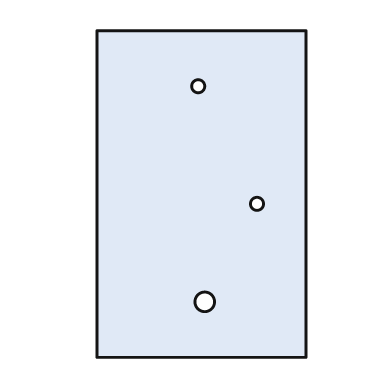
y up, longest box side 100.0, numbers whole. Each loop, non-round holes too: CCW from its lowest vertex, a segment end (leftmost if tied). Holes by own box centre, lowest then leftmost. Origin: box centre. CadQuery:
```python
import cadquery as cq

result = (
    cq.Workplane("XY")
    .moveTo(-32.0, -50.0)
    .lineTo(32.0, -50.0)
    .lineTo(32.0, 50.0)
    .lineTo(-32.0, 50.0)
    .close()
    .moveTo(1.0, -33.0)
    .circle(3.0)
    .moveTo(17.0, -3.0)
    .circle(2.0)
    .moveTo(-1.0, 33.0)
    .circle(2.0)
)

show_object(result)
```